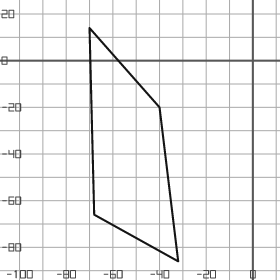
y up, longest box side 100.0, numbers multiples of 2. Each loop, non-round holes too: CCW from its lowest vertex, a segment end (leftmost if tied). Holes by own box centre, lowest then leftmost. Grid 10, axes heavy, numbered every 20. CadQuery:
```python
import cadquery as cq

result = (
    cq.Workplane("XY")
    .moveTo(-32.0, -86.0)
    .lineTo(-40.0, -20.0)
    .lineTo(-70.0, 14.0)
    .lineTo(-68.0, -66.0)
    .close()
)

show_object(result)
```